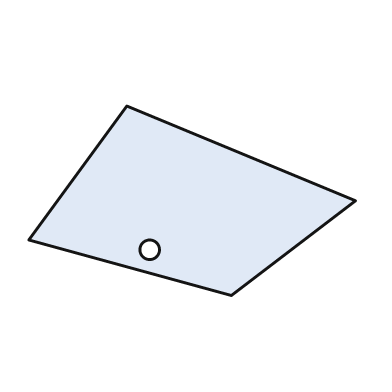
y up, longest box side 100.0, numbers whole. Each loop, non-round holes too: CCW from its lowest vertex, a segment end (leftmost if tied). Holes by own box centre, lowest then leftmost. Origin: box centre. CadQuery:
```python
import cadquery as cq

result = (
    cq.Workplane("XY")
    .moveTo(12.0, -29.0)
    .lineTo(50.0, 0.0)
    .lineTo(-20.0, 29.0)
    .lineTo(-50.0, -12.0)
    .close()
    .moveTo(-13.0, -15.0)
    .circle(3.0)
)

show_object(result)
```